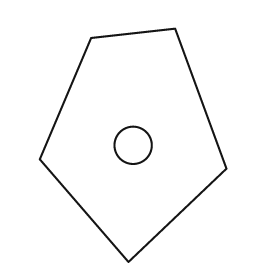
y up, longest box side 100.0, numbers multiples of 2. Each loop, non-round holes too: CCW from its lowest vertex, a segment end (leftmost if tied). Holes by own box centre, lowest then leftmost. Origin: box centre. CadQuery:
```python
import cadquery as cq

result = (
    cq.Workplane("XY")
    .moveTo(-2.0, -50.0)
    .lineTo(40.0, -10.0)
    .lineTo(18.0, 50.0)
    .lineTo(-18.0, 46.0)
    .lineTo(-40.0, -6.0)
    .close()
    .moveTo(0.0, 0.0)
    .circle(8.0)
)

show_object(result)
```